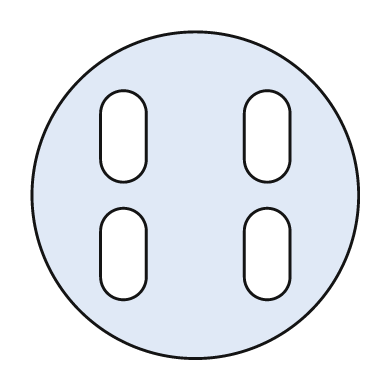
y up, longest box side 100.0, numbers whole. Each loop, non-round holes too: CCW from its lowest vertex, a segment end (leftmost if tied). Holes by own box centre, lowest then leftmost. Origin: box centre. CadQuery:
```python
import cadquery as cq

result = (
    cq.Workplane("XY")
    .moveTo(0.0, 0.0)
    .circle(50.0)
    .moveTo(-29.0, -25.0)
    .threePointArc((-22.0, -32.0), (-15.0, -25.0))
    .lineTo(-15.0, -11.0)
    .threePointArc((-22.0, -4.0), (-29.0, -11.0))
    .close()
    .moveTo(15.0, -25.0)
    .threePointArc((22.0, -32.0), (29.0, -25.0))
    .lineTo(29.0, -11.0)
    .threePointArc((22.0, -4.0), (15.0, -11.0))
    .close()
    .moveTo(-29.0, 11.0)
    .threePointArc((-22.0, 4.0), (-15.0, 11.0))
    .lineTo(-15.0, 25.0)
    .threePointArc((-22.0, 32.0), (-29.0, 25.0))
    .close()
    .moveTo(15.0, 11.0)
    .threePointArc((22.0, 4.0), (29.0, 11.0))
    .lineTo(29.0, 25.0)
    .threePointArc((22.0, 32.0), (15.0, 25.0))
    .close()
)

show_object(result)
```